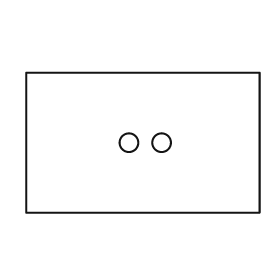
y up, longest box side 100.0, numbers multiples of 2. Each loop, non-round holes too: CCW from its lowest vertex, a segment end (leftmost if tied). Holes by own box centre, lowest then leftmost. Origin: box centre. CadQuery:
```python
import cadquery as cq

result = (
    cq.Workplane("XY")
    .moveTo(-50.0, -30.0)
    .lineTo(50.0, -30.0)
    .lineTo(50.0, 30.0)
    .lineTo(-50.0, 30.0)
    .close()
    .moveTo(-6.0, 0.0)
    .circle(4.0)
    .moveTo(8.0, 0.0)
    .circle(4.0)
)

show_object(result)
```